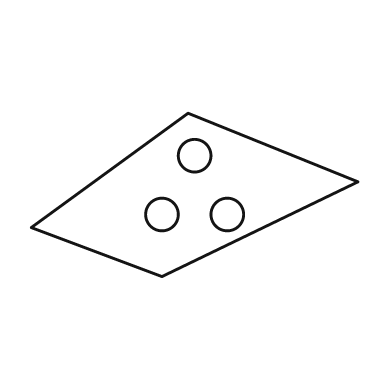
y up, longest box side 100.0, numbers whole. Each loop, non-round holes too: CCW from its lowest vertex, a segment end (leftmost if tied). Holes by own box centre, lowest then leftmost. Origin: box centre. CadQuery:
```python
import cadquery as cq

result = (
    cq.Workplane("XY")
    .moveTo(-10.0, -25.0)
    .lineTo(50.0, 4.0)
    .lineTo(-2.0, 25.0)
    .lineTo(-50.0, -10.0)
    .close()
    .moveTo(-10.0, -6.0)
    .circle(5.0)
    .moveTo(10.0, -6.0)
    .circle(5.0)
    .moveTo(0.0, 12.0)
    .circle(5.0)
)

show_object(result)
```